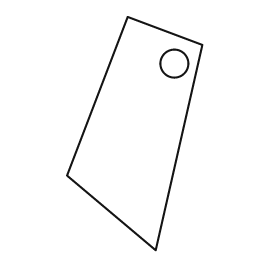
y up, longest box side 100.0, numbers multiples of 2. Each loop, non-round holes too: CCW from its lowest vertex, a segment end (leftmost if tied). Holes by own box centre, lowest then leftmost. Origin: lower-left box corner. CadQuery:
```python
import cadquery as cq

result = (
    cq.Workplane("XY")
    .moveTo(38.0, 0.0)
    .lineTo(58.0, 88.0)
    .lineTo(26.0, 100.0)
    .lineTo(0.0, 32.0)
    .close()
    .moveTo(46.0, 80.0)
    .circle(6.0)
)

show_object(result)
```